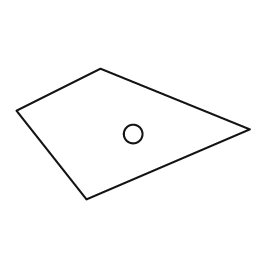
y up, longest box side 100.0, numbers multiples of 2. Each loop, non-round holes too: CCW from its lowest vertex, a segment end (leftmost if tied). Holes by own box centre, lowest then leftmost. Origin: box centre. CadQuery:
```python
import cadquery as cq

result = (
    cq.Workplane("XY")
    .moveTo(-20.0, -28.0)
    .lineTo(50.0, 2.0)
    .lineTo(-14.0, 28.0)
    .lineTo(-50.0, 10.0)
    .close()
    .moveTo(0.0, 0.0)
    .circle(4.0)
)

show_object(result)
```